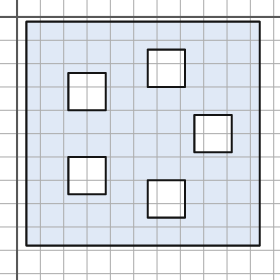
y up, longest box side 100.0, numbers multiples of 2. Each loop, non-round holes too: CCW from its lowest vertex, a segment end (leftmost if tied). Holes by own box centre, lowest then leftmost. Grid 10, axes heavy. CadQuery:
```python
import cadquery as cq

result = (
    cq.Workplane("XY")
    .moveTo(4.0, -98.0)
    .lineTo(104.0, -98.0)
    .lineTo(104.0, -2.0)
    .lineTo(4.0, -2.0)
    .close()
    .moveTo(56.0, -86.0)
    .lineTo(72.0, -86.0)
    .lineTo(72.0, -70.0)
    .lineTo(56.0, -70.0)
    .close()
    .moveTo(22.0, -76.0)
    .lineTo(38.0, -76.0)
    .lineTo(38.0, -60.0)
    .lineTo(22.0, -60.0)
    .close()
    .moveTo(76.0, -58.0)
    .lineTo(92.0, -58.0)
    .lineTo(92.0, -42.0)
    .lineTo(76.0, -42.0)
    .close()
    .moveTo(22.0, -40.0)
    .lineTo(38.0, -40.0)
    .lineTo(38.0, -24.0)
    .lineTo(22.0, -24.0)
    .close()
    .moveTo(56.0, -30.0)
    .lineTo(72.0, -30.0)
    .lineTo(72.0, -14.0)
    .lineTo(56.0, -14.0)
    .close()
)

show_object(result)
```